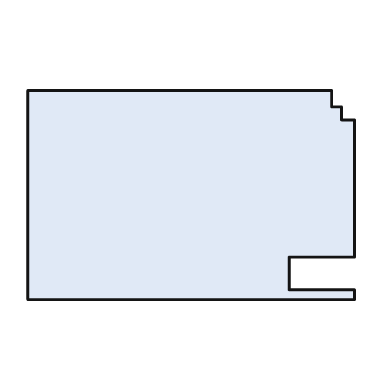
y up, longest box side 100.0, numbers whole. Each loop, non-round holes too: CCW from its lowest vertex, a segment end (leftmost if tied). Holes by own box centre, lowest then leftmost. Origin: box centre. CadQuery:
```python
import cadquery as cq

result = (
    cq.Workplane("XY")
    .moveTo(-50.0, -32.0)
    .lineTo(50.0, -32.0)
    .lineTo(50.0, -29.0)
    .lineTo(30.0, -29.0)
    .lineTo(30.0, -19.0)
    .lineTo(50.0, -19.0)
    .lineTo(50.0, 23.0)
    .lineTo(46.0, 23.0)
    .lineTo(46.0, 27.0)
    .lineTo(43.0, 27.0)
    .lineTo(43.0, 32.0)
    .lineTo(-50.0, 32.0)
    .close()
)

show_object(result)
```